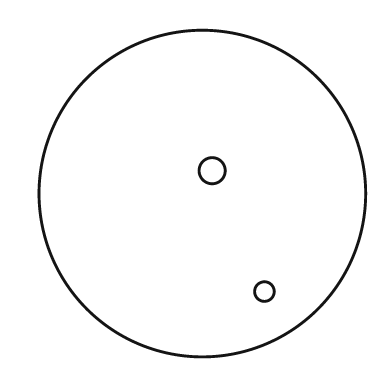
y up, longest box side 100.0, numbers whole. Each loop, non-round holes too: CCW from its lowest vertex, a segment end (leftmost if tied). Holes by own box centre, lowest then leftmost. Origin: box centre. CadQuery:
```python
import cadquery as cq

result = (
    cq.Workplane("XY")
    .moveTo(0.0, 0.0)
    .circle(50.0)
    .moveTo(19.0, -30.0)
    .circle(3.0)
    .moveTo(3.0, 7.0)
    .circle(4.0)
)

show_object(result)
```